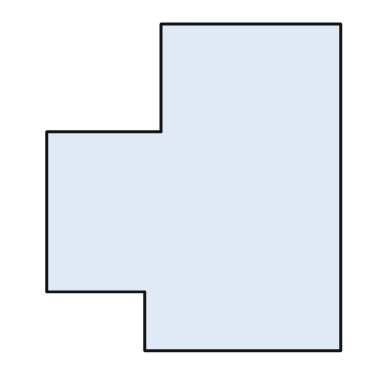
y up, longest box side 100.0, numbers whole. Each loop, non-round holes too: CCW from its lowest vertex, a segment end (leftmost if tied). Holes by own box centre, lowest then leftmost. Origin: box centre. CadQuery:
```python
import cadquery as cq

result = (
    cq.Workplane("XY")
    .moveTo(-15.0, -50.0)
    .lineTo(45.0, -50.0)
    .lineTo(45.0, 50.0)
    .lineTo(-10.0, 50.0)
    .lineTo(-10.0, 17.0)
    .lineTo(-45.0, 17.0)
    .lineTo(-45.0, -32.0)
    .lineTo(-15.0, -32.0)
    .close()
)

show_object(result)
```